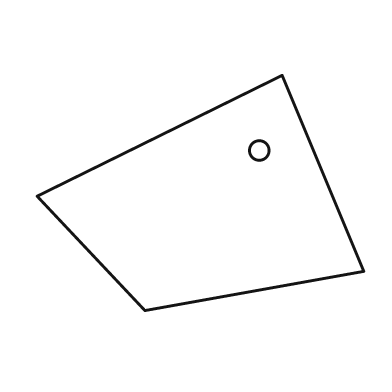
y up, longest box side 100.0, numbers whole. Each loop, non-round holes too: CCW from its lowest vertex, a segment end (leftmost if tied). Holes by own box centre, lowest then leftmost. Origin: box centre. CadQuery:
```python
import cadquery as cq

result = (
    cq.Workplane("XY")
    .moveTo(-17.0, -36.0)
    .lineTo(50.0, -24.0)
    .lineTo(25.0, 36.0)
    .lineTo(-50.0, -1.0)
    .close()
    .moveTo(18.0, 13.0)
    .circle(3.0)
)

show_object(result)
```